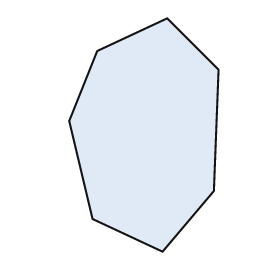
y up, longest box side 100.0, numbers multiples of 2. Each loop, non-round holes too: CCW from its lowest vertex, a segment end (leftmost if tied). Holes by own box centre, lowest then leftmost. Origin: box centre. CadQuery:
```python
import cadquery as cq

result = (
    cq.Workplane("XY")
    .moveTo(8.0, -50.0)
    .lineTo(30.0, -24.0)
    .lineTo(32.0, 28.0)
    .lineTo(10.0, 50.0)
    .lineTo(-20.0, 36.0)
    .lineTo(-32.0, 6.0)
    .lineTo(-22.0, -36.0)
    .close()
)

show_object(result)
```